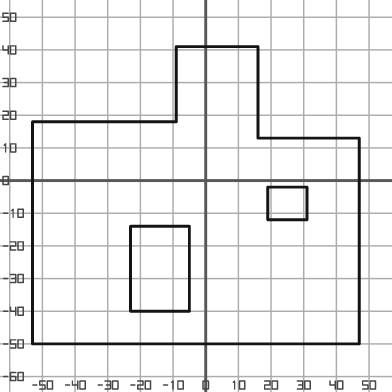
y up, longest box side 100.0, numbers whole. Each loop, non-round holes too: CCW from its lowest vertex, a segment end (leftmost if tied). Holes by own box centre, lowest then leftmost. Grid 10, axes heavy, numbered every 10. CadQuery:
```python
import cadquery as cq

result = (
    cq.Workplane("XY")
    .moveTo(-53.0, -50.0)
    .lineTo(47.0, -50.0)
    .lineTo(47.0, 13.0)
    .lineTo(16.0, 13.0)
    .lineTo(16.0, 41.0)
    .lineTo(-9.0, 41.0)
    .lineTo(-9.0, 18.0)
    .lineTo(-53.0, 18.0)
    .close()
    .moveTo(-23.0, -40.0)
    .lineTo(-5.0, -40.0)
    .lineTo(-5.0, -14.0)
    .lineTo(-23.0, -14.0)
    .close()
    .moveTo(19.0, -12.0)
    .lineTo(31.0, -12.0)
    .lineTo(31.0, -2.0)
    .lineTo(19.0, -2.0)
    .close()
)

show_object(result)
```